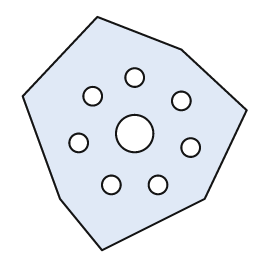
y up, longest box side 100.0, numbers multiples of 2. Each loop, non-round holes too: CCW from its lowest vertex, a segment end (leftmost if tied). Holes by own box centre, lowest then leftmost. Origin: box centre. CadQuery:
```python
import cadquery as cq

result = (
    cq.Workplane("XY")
    .moveTo(-14.0, -50.0)
    .lineTo(30.0, -28.0)
    .lineTo(48.0, 10.0)
    .lineTo(20.0, 36.0)
    .lineTo(-16.0, 50.0)
    .lineTo(-48.0, 16.0)
    .lineTo(-32.0, -28.0)
    .close()
    .moveTo(-10.0, -22.0)
    .circle(4.0)
    .moveTo(10.0, -22.0)
    .circle(4.0)
    .moveTo(24.0, -6.0)
    .circle(4.0)
    .moveTo(-24.0, -4.0)
    .circle(4.0)
    .moveTo(0.0, 0.0)
    .circle(8.0)
    .moveTo(20.0, 14.0)
    .circle(4.0)
    .moveTo(-18.0, 16.0)
    .circle(4.0)
    .moveTo(0.0, 24.0)
    .circle(4.0)
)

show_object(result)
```